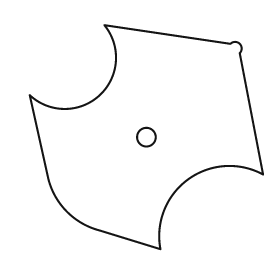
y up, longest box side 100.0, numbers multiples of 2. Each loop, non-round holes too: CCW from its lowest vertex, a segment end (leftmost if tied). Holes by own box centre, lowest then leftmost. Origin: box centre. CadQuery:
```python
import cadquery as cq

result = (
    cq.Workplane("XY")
    .moveTo(6.0, -48.0)
    .threePointArc((18.0, -18.0), (50.0, -16.0))
    .lineTo(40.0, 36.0)
    .threePointArc((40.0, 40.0), (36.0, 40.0))
    .lineTo(-18.0, 48.0)
    .threePointArc((-20.0, 18.0), (-50.0, 18.0))
    .lineTo(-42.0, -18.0)
    .threePointArc((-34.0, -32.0), (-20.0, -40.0))
    .close()
    .moveTo(0.0, 0.0)
    .circle(4.0)
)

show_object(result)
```